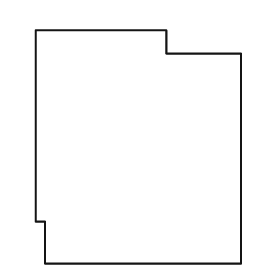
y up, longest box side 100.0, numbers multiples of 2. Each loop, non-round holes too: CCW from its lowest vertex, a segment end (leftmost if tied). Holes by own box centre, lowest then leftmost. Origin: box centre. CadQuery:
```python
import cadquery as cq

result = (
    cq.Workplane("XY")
    .moveTo(-40.0, -50.0)
    .lineTo(44.0, -50.0)
    .lineTo(44.0, 40.0)
    .lineTo(12.0, 40.0)
    .lineTo(12.0, 50.0)
    .lineTo(-44.0, 50.0)
    .lineTo(-44.0, -32.0)
    .lineTo(-40.0, -32.0)
    .close()
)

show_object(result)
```